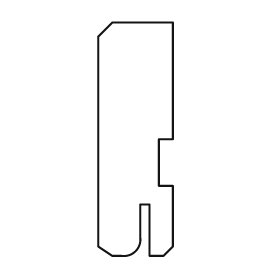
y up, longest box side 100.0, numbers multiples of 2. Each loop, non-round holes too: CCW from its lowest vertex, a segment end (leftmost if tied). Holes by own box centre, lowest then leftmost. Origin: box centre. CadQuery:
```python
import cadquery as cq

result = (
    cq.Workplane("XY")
    .moveTo(-10.0, -50.0)
    .lineTo(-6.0, -50.0)
    .threePointArc((0.0, -48.0), (2.0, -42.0))
    .lineTo(2.0, -28.0)
    .lineTo(6.0, -28.0)
    .lineTo(6.0, -50.0)
    .lineTo(12.0, -50.0)
    .lineTo(16.0, -46.0)
    .lineTo(16.0, -20.0)
    .lineTo(10.0, -20.0)
    .lineTo(10.0, 0.0)
    .lineTo(16.0, 0.0)
    .lineTo(16.0, 50.0)
    .lineTo(-10.0, 50.0)
    .lineTo(-16.0, 44.0)
    .lineTo(-16.0, -46.0)
    .close()
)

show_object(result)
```